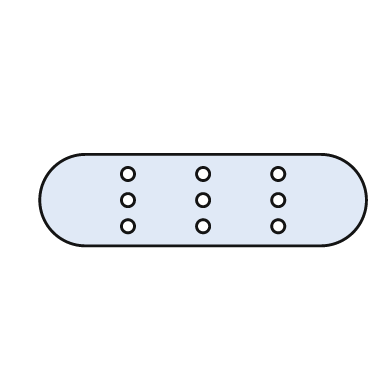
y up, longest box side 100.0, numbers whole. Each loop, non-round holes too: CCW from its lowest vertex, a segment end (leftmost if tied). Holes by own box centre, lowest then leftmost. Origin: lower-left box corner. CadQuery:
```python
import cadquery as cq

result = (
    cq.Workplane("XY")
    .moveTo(14.0, 0.0)
    .lineTo(86.0, 0.0)
    .threePointArc((100.0, 14.0), (86.0, 28.0))
    .lineTo(14.0, 28.0)
    .threePointArc((0.0, 14.0), (14.0, 0.0))
    .close()
    .moveTo(27.0, 6.0)
    .circle(2.0)
    .moveTo(50.0, 6.0)
    .circle(2.0)
    .moveTo(73.0, 6.0)
    .circle(2.0)
    .moveTo(27.0, 14.0)
    .circle(2.0)
    .moveTo(50.0, 14.0)
    .circle(2.0)
    .moveTo(73.0, 14.0)
    .circle(2.0)
    .moveTo(27.0, 22.0)
    .circle(2.0)
    .moveTo(50.0, 22.0)
    .circle(2.0)
    .moveTo(73.0, 22.0)
    .circle(2.0)
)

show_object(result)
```